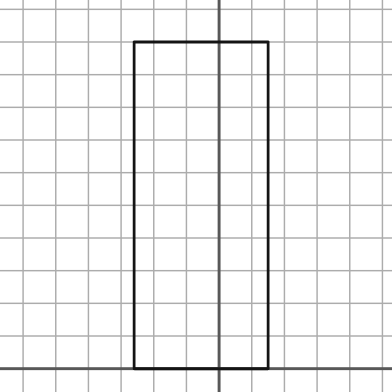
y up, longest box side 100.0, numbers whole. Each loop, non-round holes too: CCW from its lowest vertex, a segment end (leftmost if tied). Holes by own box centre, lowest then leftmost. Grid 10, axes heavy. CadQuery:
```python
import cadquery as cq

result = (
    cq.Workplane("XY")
    .moveTo(-26.0, 0.0)
    .lineTo(15.0, 0.0)
    .lineTo(15.0, 100.0)
    .lineTo(-26.0, 100.0)
    .close()
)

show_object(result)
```